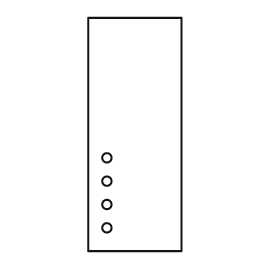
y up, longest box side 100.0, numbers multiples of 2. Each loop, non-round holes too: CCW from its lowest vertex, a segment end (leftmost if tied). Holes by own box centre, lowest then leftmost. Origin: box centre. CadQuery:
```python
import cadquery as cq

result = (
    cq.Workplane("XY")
    .moveTo(-20.0, -50.0)
    .lineTo(20.0, -50.0)
    .lineTo(20.0, 50.0)
    .lineTo(-20.0, 50.0)
    .close()
    .moveTo(-12.0, -40.0)
    .circle(2.0)
    .moveTo(-12.0, -30.0)
    .circle(2.0)
    .moveTo(-12.0, -20.0)
    .circle(2.0)
    .moveTo(-12.0, -10.0)
    .circle(2.0)
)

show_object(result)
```